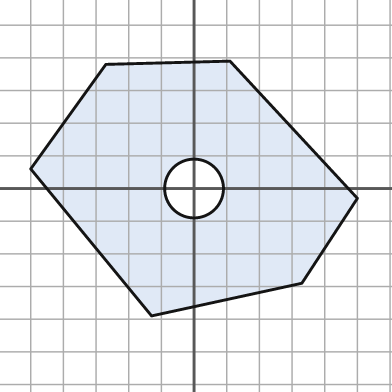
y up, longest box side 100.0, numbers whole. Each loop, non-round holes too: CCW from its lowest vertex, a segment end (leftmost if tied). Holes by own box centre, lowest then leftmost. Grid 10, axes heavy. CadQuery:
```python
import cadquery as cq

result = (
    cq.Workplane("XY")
    .moveTo(-13.0, -39.0)
    .lineTo(33.0, -29.0)
    .lineTo(50.0, -3.0)
    .lineTo(11.0, 39.0)
    .lineTo(-27.0, 38.0)
    .lineTo(-50.0, 6.0)
    .close()
    .moveTo(0.0, 0.0)
    .circle(9.0)
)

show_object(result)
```